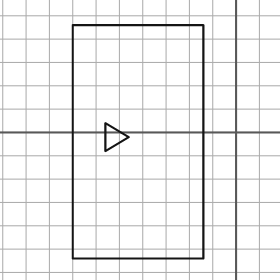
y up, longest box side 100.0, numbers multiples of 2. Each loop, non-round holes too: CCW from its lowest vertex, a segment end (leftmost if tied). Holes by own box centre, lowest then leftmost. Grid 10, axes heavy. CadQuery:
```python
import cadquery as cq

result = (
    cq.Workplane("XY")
    .moveTo(-70.0, -54.0)
    .lineTo(-14.0, -54.0)
    .lineTo(-14.0, 46.0)
    .lineTo(-70.0, 46.0)
    .close()
    .moveTo(-56.0, -8.0)
    .lineTo(-46.0, -2.0)
    .lineTo(-56.0, 4.0)
    .close()
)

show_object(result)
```